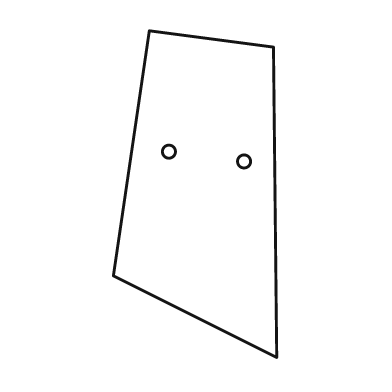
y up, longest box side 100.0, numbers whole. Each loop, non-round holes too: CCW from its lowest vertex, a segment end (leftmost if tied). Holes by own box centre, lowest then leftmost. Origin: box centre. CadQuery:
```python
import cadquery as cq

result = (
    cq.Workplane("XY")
    .moveTo(25.0, -50.0)
    .lineTo(24.0, 45.0)
    .lineTo(-14.0, 50.0)
    .lineTo(-25.0, -25.0)
    .close()
    .moveTo(15.0, 10.0)
    .circle(2.0)
    .moveTo(-8.0, 13.0)
    .circle(2.0)
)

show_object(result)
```